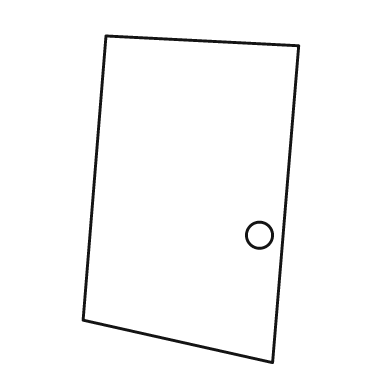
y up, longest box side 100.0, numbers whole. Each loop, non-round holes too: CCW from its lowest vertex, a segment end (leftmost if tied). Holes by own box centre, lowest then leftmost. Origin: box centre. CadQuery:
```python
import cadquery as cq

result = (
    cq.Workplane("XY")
    .moveTo(25.0, -50.0)
    .lineTo(33.0, 47.0)
    .lineTo(-26.0, 50.0)
    .lineTo(-33.0, -37.0)
    .close()
    .moveTo(21.0, -11.0)
    .circle(4.0)
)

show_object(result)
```